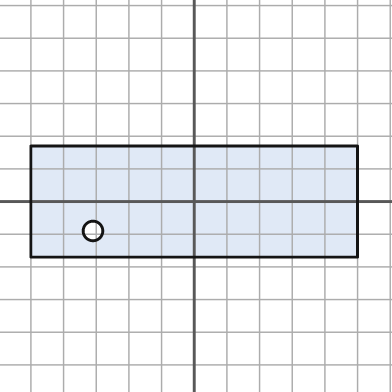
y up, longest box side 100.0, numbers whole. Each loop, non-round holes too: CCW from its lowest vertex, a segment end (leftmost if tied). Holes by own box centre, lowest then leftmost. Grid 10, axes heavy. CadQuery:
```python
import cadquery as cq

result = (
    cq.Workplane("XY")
    .moveTo(-50.0, -17.0)
    .lineTo(50.0, -17.0)
    .lineTo(50.0, 17.0)
    .lineTo(-50.0, 17.0)
    .close()
    .moveTo(-31.0, -9.0)
    .circle(3.0)
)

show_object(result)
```